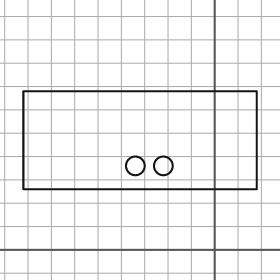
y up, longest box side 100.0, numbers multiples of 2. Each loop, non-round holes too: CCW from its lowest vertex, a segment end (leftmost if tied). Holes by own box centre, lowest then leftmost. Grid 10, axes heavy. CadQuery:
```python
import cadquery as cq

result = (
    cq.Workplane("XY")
    .moveTo(-82.0, 26.0)
    .lineTo(18.0, 26.0)
    .lineTo(18.0, 68.0)
    .lineTo(-82.0, 68.0)
    .close()
    .moveTo(-34.0, 36.0)
    .circle(4.0)
    .moveTo(-22.0, 36.0)
    .circle(4.0)
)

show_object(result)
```